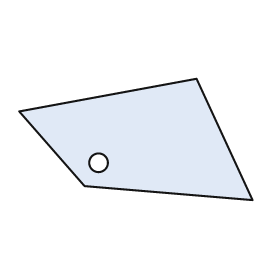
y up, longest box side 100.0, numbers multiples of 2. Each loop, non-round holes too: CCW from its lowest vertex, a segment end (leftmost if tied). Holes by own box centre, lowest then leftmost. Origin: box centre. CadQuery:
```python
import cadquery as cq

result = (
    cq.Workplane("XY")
    .moveTo(50.0, -26.0)
    .lineTo(26.0, 26.0)
    .lineTo(-50.0, 12.0)
    .lineTo(-22.0, -20.0)
    .close()
    .moveTo(-16.0, -10.0)
    .circle(4.0)
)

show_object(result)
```